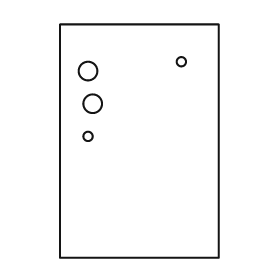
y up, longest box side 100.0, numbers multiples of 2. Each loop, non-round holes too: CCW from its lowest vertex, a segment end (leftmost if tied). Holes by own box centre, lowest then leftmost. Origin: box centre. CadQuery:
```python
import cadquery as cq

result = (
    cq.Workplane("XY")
    .moveTo(-34.0, -50.0)
    .lineTo(34.0, -50.0)
    .lineTo(34.0, 50.0)
    .lineTo(-34.0, 50.0)
    .close()
    .moveTo(-22.0, 2.0)
    .circle(2.0)
    .moveTo(-20.0, 16.0)
    .circle(4.0)
    .moveTo(-22.0, 30.0)
    .circle(4.0)
    .moveTo(18.0, 34.0)
    .circle(2.0)
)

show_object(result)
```